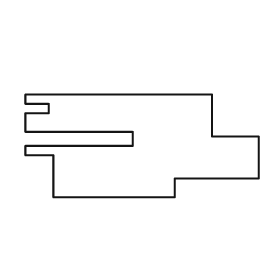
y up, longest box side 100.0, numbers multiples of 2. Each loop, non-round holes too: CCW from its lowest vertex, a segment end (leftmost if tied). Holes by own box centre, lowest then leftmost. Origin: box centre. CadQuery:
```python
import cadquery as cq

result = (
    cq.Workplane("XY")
    .moveTo(-38.0, -22.0)
    .lineTo(14.0, -22.0)
    .lineTo(14.0, -14.0)
    .lineTo(50.0, -14.0)
    .lineTo(50.0, 4.0)
    .lineTo(30.0, 4.0)
    .lineTo(30.0, 22.0)
    .lineTo(-50.0, 22.0)
    .lineTo(-50.0, 18.0)
    .lineTo(-40.0, 18.0)
    .lineTo(-40.0, 14.0)
    .lineTo(-50.0, 14.0)
    .lineTo(-50.0, 6.0)
    .lineTo(-4.0, 6.0)
    .lineTo(-4.0, 0.0)
    .lineTo(-50.0, 0.0)
    .lineTo(-50.0, -4.0)
    .lineTo(-38.0, -4.0)
    .close()
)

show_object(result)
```